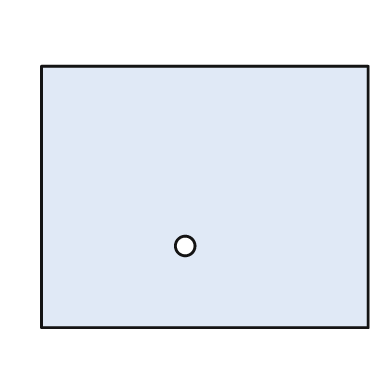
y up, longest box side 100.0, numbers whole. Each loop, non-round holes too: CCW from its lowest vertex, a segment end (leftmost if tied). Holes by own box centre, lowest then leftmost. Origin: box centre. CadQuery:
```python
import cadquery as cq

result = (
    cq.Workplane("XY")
    .moveTo(-50.0, -40.0)
    .lineTo(50.0, -40.0)
    .lineTo(50.0, 40.0)
    .lineTo(-50.0, 40.0)
    .close()
    .moveTo(-6.0, -15.0)
    .circle(3.0)
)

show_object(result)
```